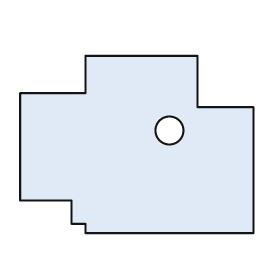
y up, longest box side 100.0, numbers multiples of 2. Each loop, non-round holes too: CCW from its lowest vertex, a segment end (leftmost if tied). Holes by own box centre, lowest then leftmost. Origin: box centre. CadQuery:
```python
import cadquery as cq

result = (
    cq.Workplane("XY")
    .moveTo(-22.0, -38.0)
    .lineTo(50.0, -38.0)
    .lineTo(50.0, 16.0)
    .lineTo(26.0, 16.0)
    .lineTo(26.0, 38.0)
    .lineTo(-22.0, 38.0)
    .lineTo(-22.0, 22.0)
    .lineTo(-50.0, 22.0)
    .lineTo(-50.0, -24.0)
    .lineTo(-28.0, -24.0)
    .lineTo(-28.0, -34.0)
    .lineTo(-22.0, -34.0)
    .close()
    .moveTo(14.0, 6.0)
    .circle(6.0)
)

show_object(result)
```